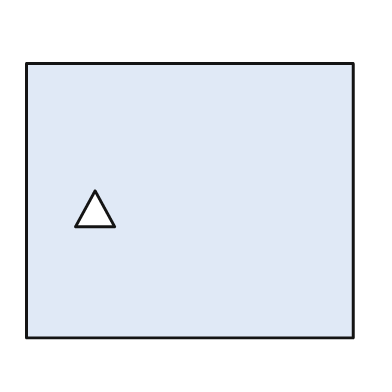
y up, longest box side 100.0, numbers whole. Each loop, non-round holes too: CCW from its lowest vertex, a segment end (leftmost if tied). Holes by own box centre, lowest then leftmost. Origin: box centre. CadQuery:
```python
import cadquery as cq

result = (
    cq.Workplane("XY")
    .moveTo(-50.0, -42.0)
    .lineTo(50.0, -42.0)
    .lineTo(50.0, 42.0)
    .lineTo(-50.0, 42.0)
    .close()
    .moveTo(-35.0, -8.0)
    .lineTo(-23.0, -8.0)
    .lineTo(-29.0, 3.0)
    .close()
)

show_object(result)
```